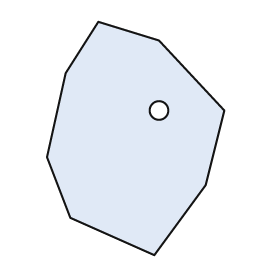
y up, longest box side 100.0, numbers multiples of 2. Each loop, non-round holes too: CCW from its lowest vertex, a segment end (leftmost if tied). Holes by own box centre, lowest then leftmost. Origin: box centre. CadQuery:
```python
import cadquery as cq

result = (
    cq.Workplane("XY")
    .moveTo(8.0, -50.0)
    .lineTo(30.0, -20.0)
    .lineTo(38.0, 12.0)
    .lineTo(10.0, 42.0)
    .lineTo(-16.0, 50.0)
    .lineTo(-30.0, 28.0)
    .lineTo(-38.0, -8.0)
    .lineTo(-28.0, -34.0)
    .close()
    .moveTo(10.0, 12.0)
    .circle(4.0)
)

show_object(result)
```